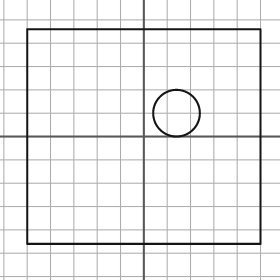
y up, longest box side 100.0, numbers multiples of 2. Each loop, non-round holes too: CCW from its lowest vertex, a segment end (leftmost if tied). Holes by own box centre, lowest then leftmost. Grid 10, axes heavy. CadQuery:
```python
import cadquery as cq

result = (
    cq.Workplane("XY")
    .moveTo(-50.0, -46.0)
    .lineTo(50.0, -46.0)
    .lineTo(50.0, 46.0)
    .lineTo(-50.0, 46.0)
    .close()
    .moveTo(14.0, 10.0)
    .circle(10.0)
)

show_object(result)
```